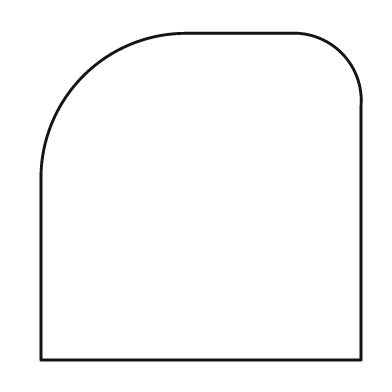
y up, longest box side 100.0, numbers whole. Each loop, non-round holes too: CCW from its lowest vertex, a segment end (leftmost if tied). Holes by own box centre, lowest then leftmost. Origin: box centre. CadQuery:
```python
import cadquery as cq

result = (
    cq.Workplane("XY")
    .moveTo(-49.0, -50.0)
    .lineTo(49.0, -50.0)
    .lineTo(49.0, 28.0)
    .threePointArc((43.0, 44.0), (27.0, 50.0))
    .lineTo(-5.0, 50.0)
    .threePointArc((-36.0, 37.0), (-49.0, 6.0))
    .close()
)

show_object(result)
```